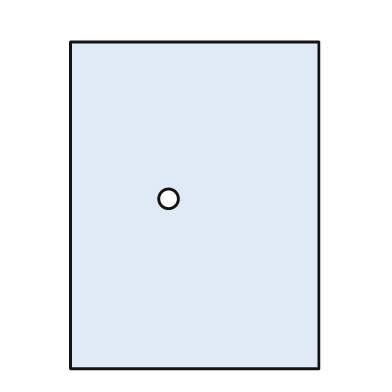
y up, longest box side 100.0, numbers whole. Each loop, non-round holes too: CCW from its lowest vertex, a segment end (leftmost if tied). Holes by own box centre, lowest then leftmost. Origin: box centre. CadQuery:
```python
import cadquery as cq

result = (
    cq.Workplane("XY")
    .moveTo(-38.0, -50.0)
    .lineTo(38.0, -50.0)
    .lineTo(38.0, 50.0)
    .lineTo(-38.0, 50.0)
    .close()
    .moveTo(-8.0, 2.0)
    .circle(3.0)
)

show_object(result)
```